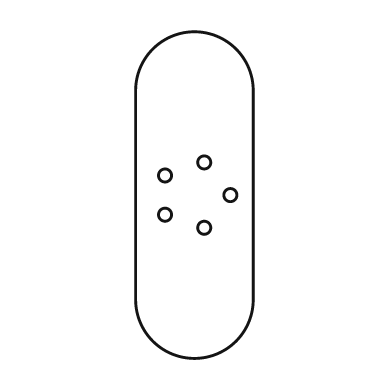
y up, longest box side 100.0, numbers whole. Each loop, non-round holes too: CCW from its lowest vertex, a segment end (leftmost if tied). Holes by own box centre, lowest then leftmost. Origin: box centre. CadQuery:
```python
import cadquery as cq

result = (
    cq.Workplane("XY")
    .moveTo(-18.0, -32.0)
    .threePointArc((0.0, -50.0), (18.0, -32.0))
    .lineTo(18.0, 32.0)
    .threePointArc((0.0, 50.0), (-18.0, 32.0))
    .close()
    .moveTo(3.0, -10.0)
    .circle(2.0)
    .moveTo(-9.0, -6.0)
    .circle(2.0)
    .moveTo(11.0, 0.0)
    .circle(2.0)
    .moveTo(-9.0, 6.0)
    .circle(2.0)
    .moveTo(3.0, 10.0)
    .circle(2.0)
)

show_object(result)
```